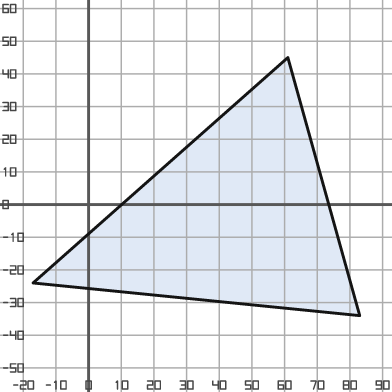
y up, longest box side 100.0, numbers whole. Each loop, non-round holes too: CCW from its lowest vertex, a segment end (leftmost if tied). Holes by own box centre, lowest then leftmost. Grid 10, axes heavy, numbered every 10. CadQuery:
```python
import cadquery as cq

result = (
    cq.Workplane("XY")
    .moveTo(83.0, -34.0)
    .lineTo(61.0, 45.0)
    .lineTo(-17.0, -24.0)
    .close()
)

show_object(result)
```